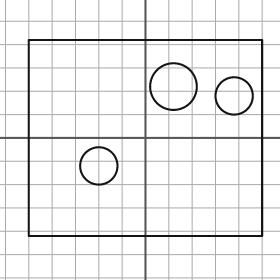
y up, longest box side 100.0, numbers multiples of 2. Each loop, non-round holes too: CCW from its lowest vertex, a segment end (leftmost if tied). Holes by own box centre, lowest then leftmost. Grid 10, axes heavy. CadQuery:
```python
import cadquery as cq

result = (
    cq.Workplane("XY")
    .moveTo(-50.0, -42.0)
    .lineTo(50.0, -42.0)
    .lineTo(50.0, 42.0)
    .lineTo(-50.0, 42.0)
    .close()
    .moveTo(-20.0, -12.0)
    .circle(8.0)
    .moveTo(38.0, 18.0)
    .circle(8.0)
    .moveTo(12.0, 22.0)
    .circle(10.0)
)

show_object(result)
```